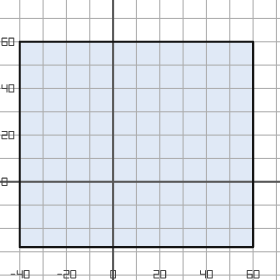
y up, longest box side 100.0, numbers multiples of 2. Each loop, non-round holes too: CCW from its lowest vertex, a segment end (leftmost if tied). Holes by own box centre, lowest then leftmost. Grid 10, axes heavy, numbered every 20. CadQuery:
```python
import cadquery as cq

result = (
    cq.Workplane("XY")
    .moveTo(-40.0, -28.0)
    .lineTo(60.0, -28.0)
    .lineTo(60.0, 60.0)
    .lineTo(-40.0, 60.0)
    .close()
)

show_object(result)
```